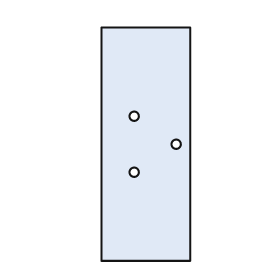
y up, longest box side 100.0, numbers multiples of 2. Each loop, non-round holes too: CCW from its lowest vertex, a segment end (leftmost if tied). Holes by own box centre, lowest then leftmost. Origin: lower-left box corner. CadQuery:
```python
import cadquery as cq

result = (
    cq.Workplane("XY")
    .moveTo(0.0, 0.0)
    .lineTo(38.0, 0.0)
    .lineTo(38.0, 100.0)
    .lineTo(0.0, 100.0)
    .close()
    .moveTo(14.0, 38.0)
    .circle(2.0)
    .moveTo(32.0, 50.0)
    .circle(2.0)
    .moveTo(14.0, 62.0)
    .circle(2.0)
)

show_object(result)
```